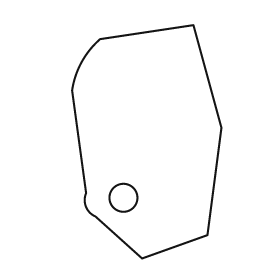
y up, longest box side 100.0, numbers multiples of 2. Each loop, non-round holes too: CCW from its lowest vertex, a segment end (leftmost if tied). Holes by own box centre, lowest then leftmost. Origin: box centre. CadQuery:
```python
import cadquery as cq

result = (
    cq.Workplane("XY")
    .moveTo(-2.0, -50.0)
    .lineTo(26.0, -40.0)
    .lineTo(32.0, 6.0)
    .lineTo(20.0, 50.0)
    .lineTo(-20.0, 44.0)
    .threePointArc((-28.0, 34.0), (-32.0, 22.0))
    .lineTo(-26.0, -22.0)
    .threePointArc((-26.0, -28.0), (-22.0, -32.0))
    .close()
    .moveTo(-10.0, -24.0)
    .circle(6.0)
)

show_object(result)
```